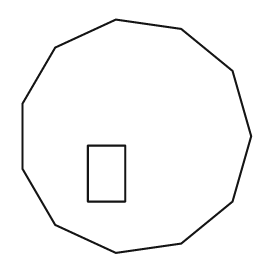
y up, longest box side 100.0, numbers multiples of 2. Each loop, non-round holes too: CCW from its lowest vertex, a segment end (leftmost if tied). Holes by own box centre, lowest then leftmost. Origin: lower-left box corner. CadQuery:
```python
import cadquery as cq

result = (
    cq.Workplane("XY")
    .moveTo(40.0, 0.0)
    .lineTo(68.0, 4.0)
    .lineTo(90.0, 22.0)
    .lineTo(98.0, 50.0)
    .lineTo(90.0, 78.0)
    .lineTo(68.0, 96.0)
    .lineTo(40.0, 100.0)
    .lineTo(14.0, 88.0)
    .lineTo(0.0, 64.0)
    .lineTo(0.0, 36.0)
    .lineTo(14.0, 12.0)
    .close()
    .moveTo(28.0, 22.0)
    .lineTo(44.0, 22.0)
    .lineTo(44.0, 46.0)
    .lineTo(28.0, 46.0)
    .close()
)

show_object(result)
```